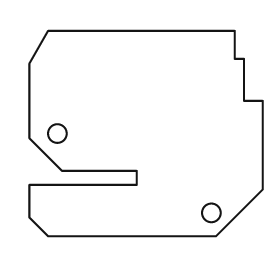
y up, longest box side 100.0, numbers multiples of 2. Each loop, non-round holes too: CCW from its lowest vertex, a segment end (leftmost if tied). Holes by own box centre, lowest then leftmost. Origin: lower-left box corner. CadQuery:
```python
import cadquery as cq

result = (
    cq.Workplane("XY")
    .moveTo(8.0, 0.0)
    .lineTo(80.0, 0.0)
    .lineTo(100.0, 20.0)
    .lineTo(100.0, 58.0)
    .lineTo(92.0, 58.0)
    .lineTo(92.0, 76.0)
    .lineTo(88.0, 76.0)
    .lineTo(88.0, 88.0)
    .lineTo(8.0, 88.0)
    .lineTo(0.0, 74.0)
    .lineTo(0.0, 42.0)
    .lineTo(14.0, 28.0)
    .lineTo(46.0, 28.0)
    .lineTo(46.0, 22.0)
    .lineTo(0.0, 22.0)
    .lineTo(0.0, 8.0)
    .close()
    .moveTo(78.0, 10.0)
    .circle(4.0)
    .moveTo(12.0, 44.0)
    .circle(4.0)
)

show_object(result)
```